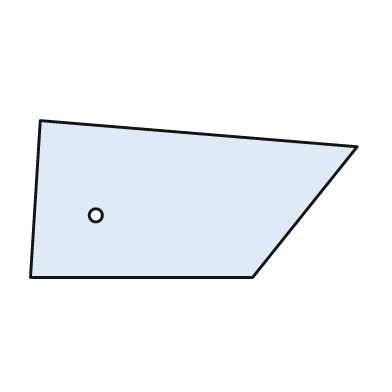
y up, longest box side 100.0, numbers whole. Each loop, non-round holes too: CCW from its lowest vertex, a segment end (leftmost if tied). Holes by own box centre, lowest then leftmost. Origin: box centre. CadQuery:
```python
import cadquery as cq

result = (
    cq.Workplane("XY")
    .moveTo(-50.0, -24.0)
    .lineTo(18.0, -24.0)
    .lineTo(50.0, 16.0)
    .lineTo(-47.0, 24.0)
    .close()
    .moveTo(-30.0, -5.0)
    .circle(2.0)
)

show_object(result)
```